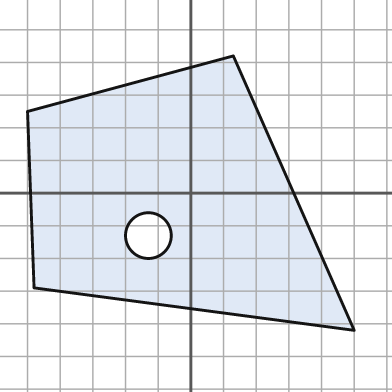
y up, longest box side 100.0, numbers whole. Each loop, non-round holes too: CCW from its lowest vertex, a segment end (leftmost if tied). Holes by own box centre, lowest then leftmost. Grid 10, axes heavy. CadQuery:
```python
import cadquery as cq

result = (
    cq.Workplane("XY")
    .moveTo(50.0, -42.0)
    .lineTo(13.0, 42.0)
    .lineTo(-50.0, 25.0)
    .lineTo(-48.0, -29.0)
    .close()
    .moveTo(-13.0, -13.0)
    .circle(7.0)
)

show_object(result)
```